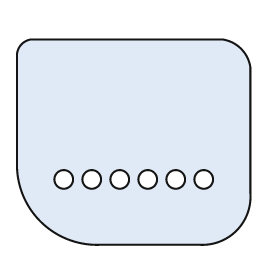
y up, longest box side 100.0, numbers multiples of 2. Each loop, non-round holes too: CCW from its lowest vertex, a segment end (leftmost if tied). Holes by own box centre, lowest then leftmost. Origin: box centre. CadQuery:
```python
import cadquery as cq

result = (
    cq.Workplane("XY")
    .moveTo(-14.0, -44.0)
    .lineTo(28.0, -44.0)
    .threePointArc((44.0, -38.0), (50.0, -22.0))
    .lineTo(50.0, 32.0)
    .threePointArc((46.0, 40.0), (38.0, 44.0))
    .lineTo(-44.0, 44.0)
    .threePointArc((-48.0, 42.0), (-50.0, 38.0))
    .lineTo(-50.0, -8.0)
    .threePointArc((-40.0, -34.0), (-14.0, -44.0))
    .close()
    .moveTo(-30.0, -16.0)
    .circle(4.0)
    .moveTo(-18.0, -16.0)
    .circle(4.0)
    .moveTo(-6.0, -16.0)
    .circle(4.0)
    .moveTo(6.0, -16.0)
    .circle(4.0)
    .moveTo(18.0, -16.0)
    .circle(4.0)
    .moveTo(30.0, -16.0)
    .circle(4.0)
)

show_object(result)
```